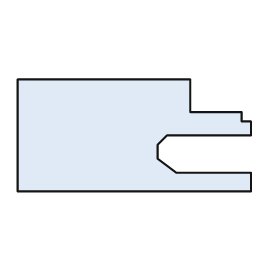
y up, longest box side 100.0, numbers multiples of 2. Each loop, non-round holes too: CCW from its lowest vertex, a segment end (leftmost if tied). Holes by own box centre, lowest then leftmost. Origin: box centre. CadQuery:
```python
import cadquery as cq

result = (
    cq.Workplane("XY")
    .moveTo(-50.0, -24.0)
    .lineTo(50.0, -24.0)
    .lineTo(50.0, -16.0)
    .lineTo(18.0, -16.0)
    .lineTo(10.0, -10.0)
    .lineTo(10.0, -4.0)
    .lineTo(14.0, 0.0)
    .lineTo(50.0, 0.0)
    .lineTo(50.0, 6.0)
    .lineTo(46.0, 6.0)
    .lineTo(46.0, 10.0)
    .lineTo(24.0, 10.0)
    .lineTo(24.0, 24.0)
    .lineTo(-50.0, 24.0)
    .close()
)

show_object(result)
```